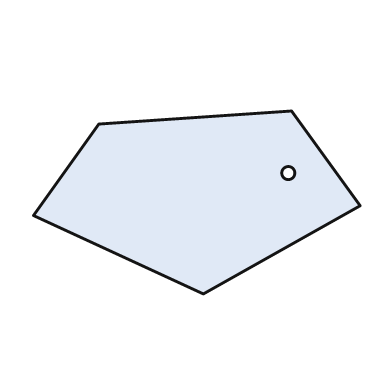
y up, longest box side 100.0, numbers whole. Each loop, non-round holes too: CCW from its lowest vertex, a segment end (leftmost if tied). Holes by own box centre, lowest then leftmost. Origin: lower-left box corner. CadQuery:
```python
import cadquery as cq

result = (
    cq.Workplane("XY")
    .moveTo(52.0, 0.0)
    .lineTo(100.0, 27.0)
    .lineTo(79.0, 56.0)
    .lineTo(20.0, 52.0)
    .lineTo(0.0, 24.0)
    .close()
    .moveTo(78.0, 37.0)
    .circle(2.0)
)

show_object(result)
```